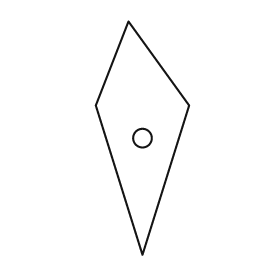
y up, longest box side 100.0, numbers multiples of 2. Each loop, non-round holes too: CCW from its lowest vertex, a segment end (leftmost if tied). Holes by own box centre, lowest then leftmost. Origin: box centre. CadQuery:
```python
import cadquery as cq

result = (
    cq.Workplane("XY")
    .moveTo(0.0, -50.0)
    .lineTo(20.0, 14.0)
    .lineTo(-6.0, 50.0)
    .lineTo(-20.0, 14.0)
    .close()
    .moveTo(0.0, 0.0)
    .circle(4.0)
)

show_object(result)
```